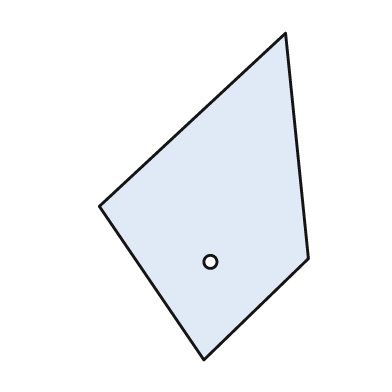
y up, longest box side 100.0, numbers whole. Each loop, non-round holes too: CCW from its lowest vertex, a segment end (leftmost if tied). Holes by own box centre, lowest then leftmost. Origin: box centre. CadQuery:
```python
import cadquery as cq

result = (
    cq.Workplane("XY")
    .moveTo(0.0, -50.0)
    .lineTo(32.0, -19.0)
    .lineTo(25.0, 50.0)
    .lineTo(-32.0, -3.0)
    .close()
    .moveTo(2.0, -20.0)
    .circle(2.0)
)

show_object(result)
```